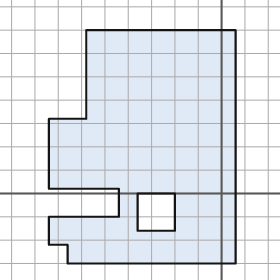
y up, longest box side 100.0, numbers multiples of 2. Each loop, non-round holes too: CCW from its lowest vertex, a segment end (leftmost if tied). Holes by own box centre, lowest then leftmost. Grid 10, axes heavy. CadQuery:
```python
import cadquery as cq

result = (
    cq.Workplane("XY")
    .moveTo(-66.0, -30.0)
    .lineTo(6.0, -30.0)
    .lineTo(6.0, 70.0)
    .lineTo(-58.0, 70.0)
    .lineTo(-58.0, 32.0)
    .lineTo(-74.0, 32.0)
    .lineTo(-74.0, 2.0)
    .lineTo(-44.0, 2.0)
    .lineTo(-44.0, -10.0)
    .lineTo(-74.0, -10.0)
    .lineTo(-74.0, -22.0)
    .lineTo(-66.0, -22.0)
    .close()
    .moveTo(-36.0, -16.0)
    .lineTo(-20.0, -16.0)
    .lineTo(-20.0, 0.0)
    .lineTo(-36.0, 0.0)
    .close()
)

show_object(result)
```